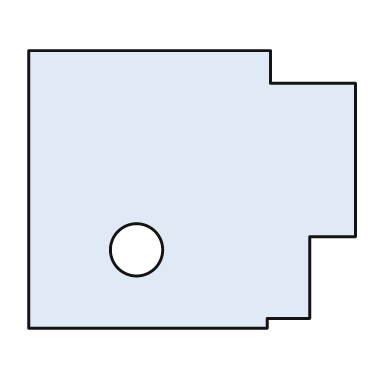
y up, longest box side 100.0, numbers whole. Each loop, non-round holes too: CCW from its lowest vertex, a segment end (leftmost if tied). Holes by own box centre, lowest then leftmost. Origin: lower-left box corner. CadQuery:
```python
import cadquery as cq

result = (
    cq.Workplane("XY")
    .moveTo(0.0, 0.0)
    .lineTo(73.0, 0.0)
    .lineTo(73.0, 3.0)
    .lineTo(86.0, 3.0)
    .lineTo(86.0, 28.0)
    .lineTo(100.0, 28.0)
    .lineTo(100.0, 75.0)
    .lineTo(74.0, 75.0)
    .lineTo(74.0, 85.0)
    .lineTo(0.0, 85.0)
    .close()
    .moveTo(33.0, 24.0)
    .circle(8.0)
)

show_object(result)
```